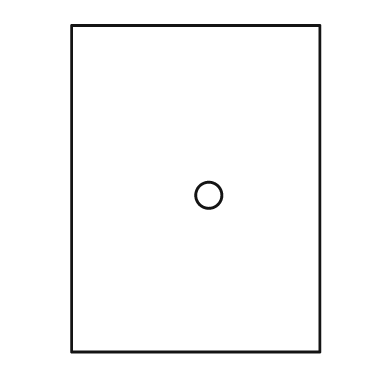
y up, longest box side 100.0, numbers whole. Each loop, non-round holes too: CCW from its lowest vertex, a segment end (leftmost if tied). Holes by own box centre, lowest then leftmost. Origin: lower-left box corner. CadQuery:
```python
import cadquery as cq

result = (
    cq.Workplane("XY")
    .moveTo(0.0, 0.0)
    .lineTo(76.0, 0.0)
    .lineTo(76.0, 100.0)
    .lineTo(0.0, 100.0)
    .close()
    .moveTo(42.0, 48.0)
    .circle(4.0)
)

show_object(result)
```